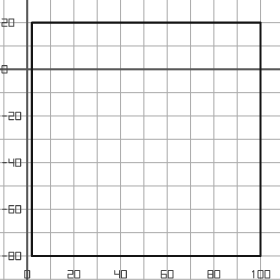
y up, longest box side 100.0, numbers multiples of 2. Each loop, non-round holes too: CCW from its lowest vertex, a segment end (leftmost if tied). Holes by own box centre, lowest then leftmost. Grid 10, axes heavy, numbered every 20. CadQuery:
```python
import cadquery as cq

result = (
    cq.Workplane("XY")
    .moveTo(2.0, -80.0)
    .lineTo(100.0, -80.0)
    .lineTo(100.0, 20.0)
    .lineTo(2.0, 20.0)
    .close()
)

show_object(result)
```